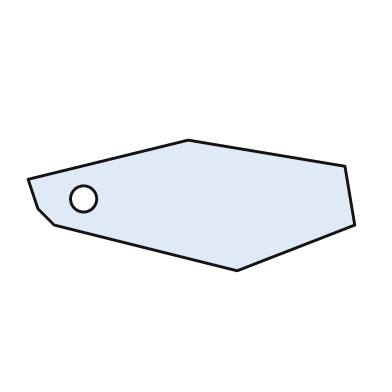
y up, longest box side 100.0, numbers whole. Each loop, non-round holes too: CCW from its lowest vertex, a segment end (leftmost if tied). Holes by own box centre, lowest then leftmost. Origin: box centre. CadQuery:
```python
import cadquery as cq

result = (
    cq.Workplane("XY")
    .moveTo(14.0, -20.0)
    .lineTo(50.0, -6.0)
    .lineTo(47.0, 12.0)
    .lineTo(-1.0, 20.0)
    .lineTo(-50.0, 8.0)
    .lineTo(-47.0, -1.0)
    .lineTo(-42.0, -6.0)
    .close()
    .moveTo(-33.0, 2.0)
    .circle(4.0)
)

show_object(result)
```